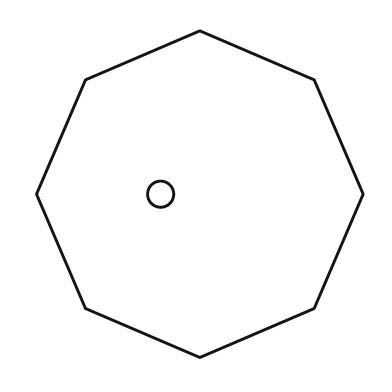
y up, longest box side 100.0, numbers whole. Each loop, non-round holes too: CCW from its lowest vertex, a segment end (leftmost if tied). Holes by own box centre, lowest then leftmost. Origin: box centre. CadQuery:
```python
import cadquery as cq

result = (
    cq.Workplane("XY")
    .moveTo(0.0, -50.0)
    .lineTo(35.0, -35.0)
    .lineTo(50.0, 0.0)
    .lineTo(35.0, 35.0)
    .lineTo(0.0, 50.0)
    .lineTo(-35.0, 35.0)
    .lineTo(-50.0, 0.0)
    .lineTo(-35.0, -35.0)
    .close()
    .moveTo(-12.0, 0.0)
    .circle(4.0)
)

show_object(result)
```